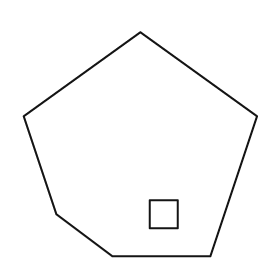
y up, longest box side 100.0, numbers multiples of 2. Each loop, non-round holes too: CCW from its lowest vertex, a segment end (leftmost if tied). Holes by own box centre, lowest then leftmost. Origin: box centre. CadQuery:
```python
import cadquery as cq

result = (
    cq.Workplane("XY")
    .moveTo(-12.0, -48.0)
    .lineTo(30.0, -48.0)
    .lineTo(50.0, 12.0)
    .lineTo(0.0, 48.0)
    .lineTo(-50.0, 12.0)
    .lineTo(-36.0, -30.0)
    .close()
    .moveTo(4.0, -36.0)
    .lineTo(16.0, -36.0)
    .lineTo(16.0, -24.0)
    .lineTo(4.0, -24.0)
    .close()
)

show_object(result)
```